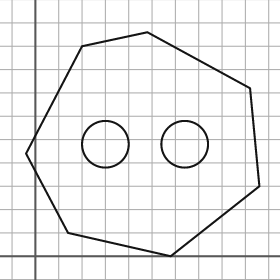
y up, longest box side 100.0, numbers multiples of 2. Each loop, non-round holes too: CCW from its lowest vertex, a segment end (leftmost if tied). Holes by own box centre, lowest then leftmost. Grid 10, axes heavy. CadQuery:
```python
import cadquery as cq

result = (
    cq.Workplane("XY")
    .moveTo(58.0, 0.0)
    .lineTo(96.0, 30.0)
    .lineTo(92.0, 72.0)
    .lineTo(48.0, 96.0)
    .lineTo(20.0, 90.0)
    .lineTo(-4.0, 44.0)
    .lineTo(14.0, 10.0)
    .close()
    .moveTo(30.0, 48.0)
    .circle(10.0)
    .moveTo(64.0, 48.0)
    .circle(10.0)
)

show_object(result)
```